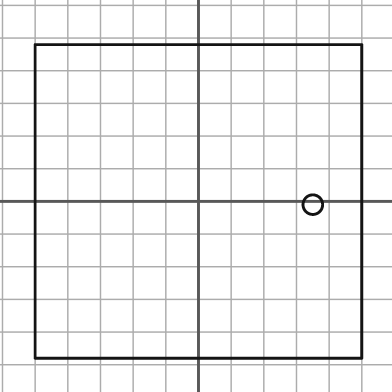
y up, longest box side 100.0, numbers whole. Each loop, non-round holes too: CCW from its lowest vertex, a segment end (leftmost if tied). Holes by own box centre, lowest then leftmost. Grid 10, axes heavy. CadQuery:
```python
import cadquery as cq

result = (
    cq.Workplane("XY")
    .moveTo(-50.0, -48.0)
    .lineTo(50.0, -48.0)
    .lineTo(50.0, 48.0)
    .lineTo(-50.0, 48.0)
    .close()
    .moveTo(35.0, -1.0)
    .circle(3.0)
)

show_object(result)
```